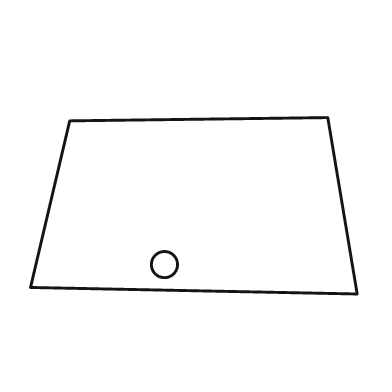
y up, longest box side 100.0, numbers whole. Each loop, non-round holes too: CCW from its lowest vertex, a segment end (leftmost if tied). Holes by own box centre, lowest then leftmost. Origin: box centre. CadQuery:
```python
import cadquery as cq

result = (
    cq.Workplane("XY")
    .moveTo(50.0, -27.0)
    .lineTo(41.0, 27.0)
    .lineTo(-38.0, 26.0)
    .lineTo(-50.0, -25.0)
    .close()
    .moveTo(-9.0, -18.0)
    .circle(4.0)
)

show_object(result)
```